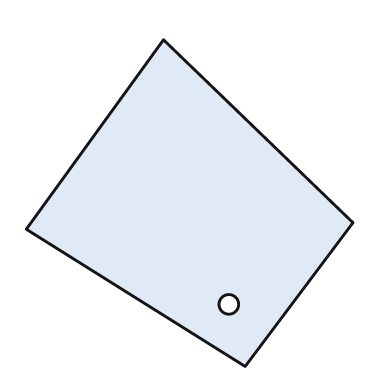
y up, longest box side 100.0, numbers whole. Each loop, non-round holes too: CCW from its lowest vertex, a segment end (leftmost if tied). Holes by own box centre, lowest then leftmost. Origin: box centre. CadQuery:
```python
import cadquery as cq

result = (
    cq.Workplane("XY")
    .moveTo(17.0, -50.0)
    .lineTo(50.0, -6.0)
    .lineTo(-8.0, 50.0)
    .lineTo(-50.0, -8.0)
    .close()
    .moveTo(12.0, -31.0)
    .circle(3.0)
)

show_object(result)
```